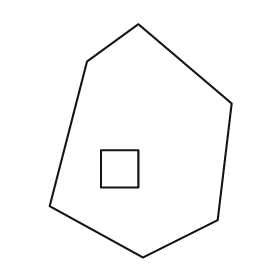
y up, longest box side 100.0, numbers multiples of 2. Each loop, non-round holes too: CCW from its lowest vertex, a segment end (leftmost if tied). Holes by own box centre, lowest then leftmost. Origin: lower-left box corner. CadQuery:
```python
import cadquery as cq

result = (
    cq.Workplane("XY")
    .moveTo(40.0, 0.0)
    .lineTo(72.0, 16.0)
    .lineTo(78.0, 66.0)
    .lineTo(38.0, 100.0)
    .lineTo(16.0, 84.0)
    .lineTo(0.0, 22.0)
    .close()
    .moveTo(22.0, 30.0)
    .lineTo(38.0, 30.0)
    .lineTo(38.0, 46.0)
    .lineTo(22.0, 46.0)
    .close()
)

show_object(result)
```